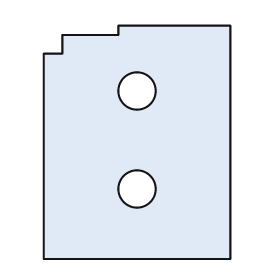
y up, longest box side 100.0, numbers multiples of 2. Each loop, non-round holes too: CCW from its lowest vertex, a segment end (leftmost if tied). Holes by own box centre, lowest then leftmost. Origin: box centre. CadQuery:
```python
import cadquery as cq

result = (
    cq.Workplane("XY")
    .moveTo(-40.0, -50.0)
    .lineTo(40.0, -50.0)
    .lineTo(40.0, 50.0)
    .lineTo(-8.0, 50.0)
    .lineTo(-8.0, 46.0)
    .lineTo(-32.0, 46.0)
    .lineTo(-32.0, 38.0)
    .lineTo(-40.0, 38.0)
    .close()
    .moveTo(0.0, -20.0)
    .circle(8.0)
    .moveTo(0.0, 22.0)
    .circle(8.0)
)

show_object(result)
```